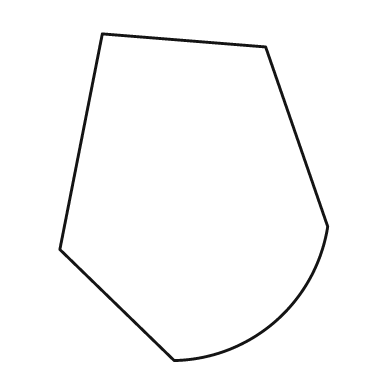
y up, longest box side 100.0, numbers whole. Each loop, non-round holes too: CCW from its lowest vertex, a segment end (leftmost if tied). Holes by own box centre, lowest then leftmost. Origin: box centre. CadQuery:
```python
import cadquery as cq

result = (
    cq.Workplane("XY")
    .moveTo(-6.0, -50.0)
    .threePointArc((25.0, -38.0), (41.0, -9.0))
    .lineTo(22.0, 46.0)
    .lineTo(-28.0, 50.0)
    .lineTo(-41.0, -16.0)
    .close()
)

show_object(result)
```